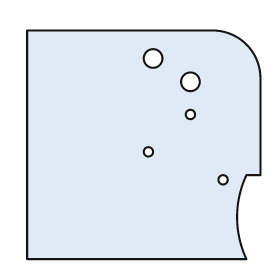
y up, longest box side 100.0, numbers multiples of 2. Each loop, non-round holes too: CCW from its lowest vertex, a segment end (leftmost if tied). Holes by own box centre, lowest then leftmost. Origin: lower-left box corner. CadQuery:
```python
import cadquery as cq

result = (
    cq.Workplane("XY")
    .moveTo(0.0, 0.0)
    .lineTo(94.0, 0.0)
    .threePointArc((90.0, 18.0), (94.0, 36.0))
    .lineTo(100.0, 36.0)
    .lineTo(100.0, 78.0)
    .threePointArc((94.0, 92.0), (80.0, 98.0))
    .lineTo(0.0, 98.0)
    .close()
    .moveTo(84.0, 34.0)
    .circle(2.0)
    .moveTo(52.0, 46.0)
    .circle(2.0)
    .moveTo(70.0, 62.0)
    .circle(2.0)
    .moveTo(70.0, 76.0)
    .circle(4.0)
    .moveTo(54.0, 86.0)
    .circle(4.0)
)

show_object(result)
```